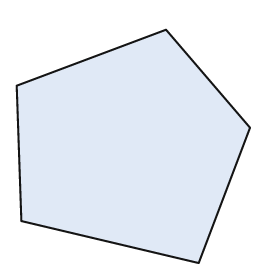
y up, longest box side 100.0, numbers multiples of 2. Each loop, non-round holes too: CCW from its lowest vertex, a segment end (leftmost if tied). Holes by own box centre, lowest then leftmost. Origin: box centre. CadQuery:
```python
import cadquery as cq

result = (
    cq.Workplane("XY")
    .moveTo(28.0, -50.0)
    .lineTo(50.0, 8.0)
    .lineTo(14.0, 50.0)
    .lineTo(-50.0, 26.0)
    .lineTo(-48.0, -32.0)
    .close()
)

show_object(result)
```